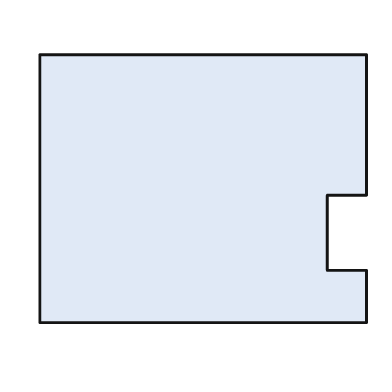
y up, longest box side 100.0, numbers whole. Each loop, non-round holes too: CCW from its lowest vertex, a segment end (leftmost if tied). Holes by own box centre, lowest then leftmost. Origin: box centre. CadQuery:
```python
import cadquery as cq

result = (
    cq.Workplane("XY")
    .moveTo(-50.0, -41.0)
    .lineTo(50.0, -41.0)
    .lineTo(50.0, -25.0)
    .lineTo(38.0, -25.0)
    .lineTo(38.0, -2.0)
    .lineTo(50.0, -2.0)
    .lineTo(50.0, 41.0)
    .lineTo(-50.0, 41.0)
    .close()
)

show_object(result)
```